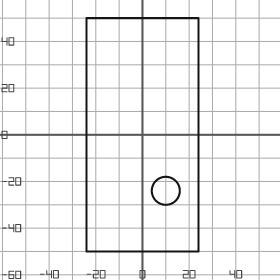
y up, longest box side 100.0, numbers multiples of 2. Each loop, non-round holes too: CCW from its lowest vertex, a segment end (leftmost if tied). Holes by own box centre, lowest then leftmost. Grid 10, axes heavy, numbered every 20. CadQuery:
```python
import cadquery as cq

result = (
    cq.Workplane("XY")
    .moveTo(-24.0, -50.0)
    .lineTo(24.0, -50.0)
    .lineTo(24.0, 50.0)
    .lineTo(-24.0, 50.0)
    .close()
    .moveTo(10.0, -24.0)
    .circle(6.0)
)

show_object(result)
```